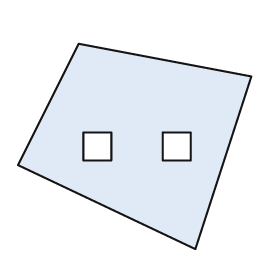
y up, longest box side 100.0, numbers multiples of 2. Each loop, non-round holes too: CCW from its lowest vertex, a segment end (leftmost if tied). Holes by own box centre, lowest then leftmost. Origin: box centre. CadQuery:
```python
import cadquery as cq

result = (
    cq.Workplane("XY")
    .moveTo(26.0, -44.0)
    .lineTo(50.0, 30.0)
    .lineTo(-24.0, 44.0)
    .lineTo(-50.0, -8.0)
    .close()
    .moveTo(-22.0, -6.0)
    .lineTo(-10.0, -6.0)
    .lineTo(-10.0, 6.0)
    .lineTo(-22.0, 6.0)
    .close()
    .moveTo(12.0, -6.0)
    .lineTo(24.0, -6.0)
    .lineTo(24.0, 6.0)
    .lineTo(12.0, 6.0)
    .close()
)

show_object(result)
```